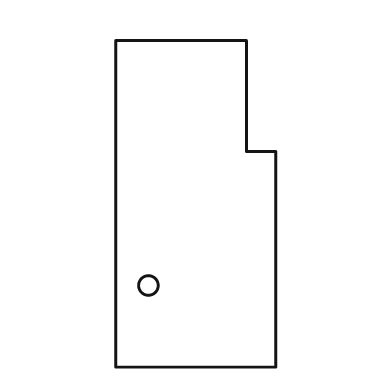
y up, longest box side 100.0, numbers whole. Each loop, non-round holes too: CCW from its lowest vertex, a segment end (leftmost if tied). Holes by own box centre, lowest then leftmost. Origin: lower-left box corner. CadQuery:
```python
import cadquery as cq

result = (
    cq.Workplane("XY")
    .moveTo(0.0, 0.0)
    .lineTo(49.0, 0.0)
    .lineTo(49.0, 66.0)
    .lineTo(40.0, 66.0)
    .lineTo(40.0, 100.0)
    .lineTo(0.0, 100.0)
    .close()
    .moveTo(10.0, 25.0)
    .circle(3.0)
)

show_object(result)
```